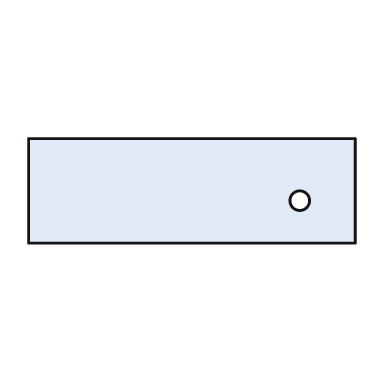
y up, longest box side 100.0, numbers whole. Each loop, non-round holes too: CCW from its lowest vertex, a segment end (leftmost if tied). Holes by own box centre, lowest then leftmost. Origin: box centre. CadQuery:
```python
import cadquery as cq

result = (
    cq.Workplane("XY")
    .moveTo(-50.0, -16.0)
    .lineTo(50.0, -16.0)
    .lineTo(50.0, 16.0)
    .lineTo(-50.0, 16.0)
    .close()
    .moveTo(33.0, -3.0)
    .circle(3.0)
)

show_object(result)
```